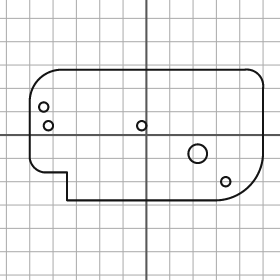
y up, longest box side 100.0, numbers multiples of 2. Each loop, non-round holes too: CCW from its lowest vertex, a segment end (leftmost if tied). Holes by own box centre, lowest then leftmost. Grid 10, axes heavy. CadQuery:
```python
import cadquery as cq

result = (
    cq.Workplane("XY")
    .moveTo(-34.0, -28.0)
    .lineTo(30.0, -28.0)
    .threePointArc((44.0, -22.0), (50.0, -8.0))
    .lineTo(50.0, 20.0)
    .threePointArc((48.0, 26.0), (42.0, 28.0))
    .lineTo(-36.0, 28.0)
    .threePointArc((-46.0, 24.0), (-50.0, 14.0))
    .lineTo(-50.0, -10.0)
    .threePointArc((-48.0, -14.0), (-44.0, -16.0))
    .lineTo(-34.0, -16.0)
    .close()
    .moveTo(34.0, -20.0)
    .circle(2.0)
    .moveTo(22.0, -8.0)
    .circle(4.0)
    .moveTo(-42.0, 4.0)
    .circle(2.0)
    .moveTo(-2.0, 4.0)
    .circle(2.0)
    .moveTo(-44.0, 12.0)
    .circle(2.0)
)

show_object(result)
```